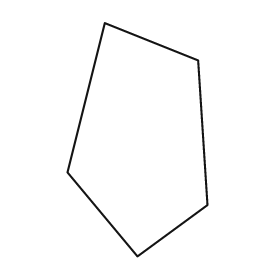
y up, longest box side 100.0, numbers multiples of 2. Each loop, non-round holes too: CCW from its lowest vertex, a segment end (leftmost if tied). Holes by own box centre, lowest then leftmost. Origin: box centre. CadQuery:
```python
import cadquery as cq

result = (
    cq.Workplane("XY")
    .moveTo(0.0, -50.0)
    .lineTo(30.0, -28.0)
    .lineTo(26.0, 34.0)
    .lineTo(-14.0, 50.0)
    .lineTo(-30.0, -14.0)
    .close()
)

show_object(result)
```